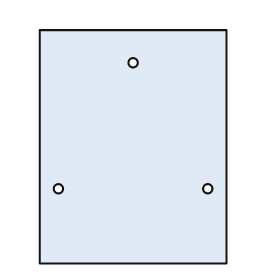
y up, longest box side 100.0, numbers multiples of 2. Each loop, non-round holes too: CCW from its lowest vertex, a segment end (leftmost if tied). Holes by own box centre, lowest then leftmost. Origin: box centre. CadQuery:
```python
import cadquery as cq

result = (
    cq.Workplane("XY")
    .moveTo(-40.0, -50.0)
    .lineTo(40.0, -50.0)
    .lineTo(40.0, 50.0)
    .lineTo(-40.0, 50.0)
    .close()
    .moveTo(-32.0, -18.0)
    .circle(2.0)
    .moveTo(32.0, -18.0)
    .circle(2.0)
    .moveTo(0.0, 36.0)
    .circle(2.0)
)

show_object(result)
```